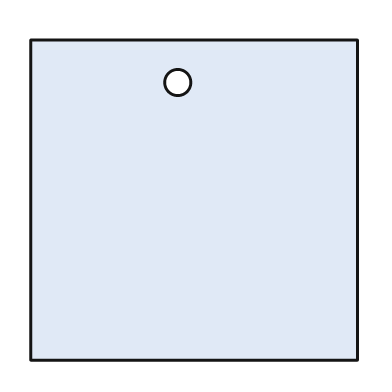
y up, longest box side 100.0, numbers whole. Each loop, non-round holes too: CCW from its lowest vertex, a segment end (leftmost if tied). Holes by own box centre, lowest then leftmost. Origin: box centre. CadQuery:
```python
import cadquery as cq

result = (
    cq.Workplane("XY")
    .moveTo(-50.0, -49.0)
    .lineTo(50.0, -49.0)
    .lineTo(50.0, 49.0)
    .lineTo(-50.0, 49.0)
    .close()
    .moveTo(-5.0, 36.0)
    .circle(4.0)
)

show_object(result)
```